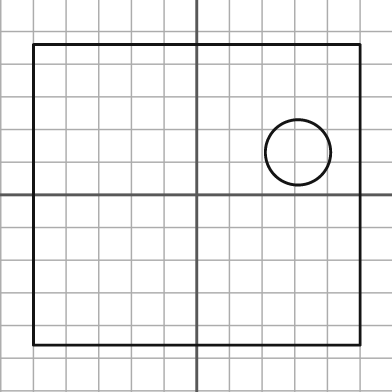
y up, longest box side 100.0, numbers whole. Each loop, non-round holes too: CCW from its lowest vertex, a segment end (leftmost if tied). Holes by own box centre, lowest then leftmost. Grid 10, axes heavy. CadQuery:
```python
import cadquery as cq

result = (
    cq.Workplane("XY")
    .moveTo(-50.0, -46.0)
    .lineTo(50.0, -46.0)
    .lineTo(50.0, 46.0)
    .lineTo(-50.0, 46.0)
    .close()
    .moveTo(31.0, 13.0)
    .circle(10.0)
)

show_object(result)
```